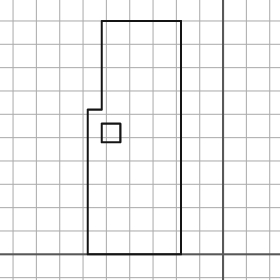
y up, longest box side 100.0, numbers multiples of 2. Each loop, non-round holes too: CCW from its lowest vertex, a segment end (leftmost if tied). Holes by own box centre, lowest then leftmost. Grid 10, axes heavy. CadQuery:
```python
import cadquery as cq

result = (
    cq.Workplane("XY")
    .moveTo(-58.0, 0.0)
    .lineTo(-18.0, 0.0)
    .lineTo(-18.0, 100.0)
    .lineTo(-52.0, 100.0)
    .lineTo(-52.0, 62.0)
    .lineTo(-58.0, 62.0)
    .close()
    .moveTo(-52.0, 48.0)
    .lineTo(-44.0, 48.0)
    .lineTo(-44.0, 56.0)
    .lineTo(-52.0, 56.0)
    .close()
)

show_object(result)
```